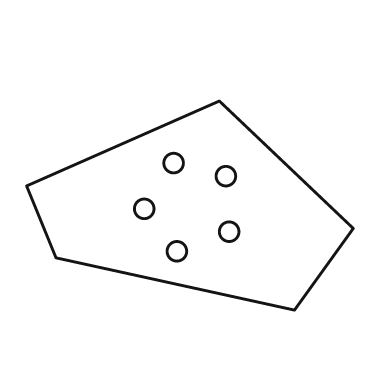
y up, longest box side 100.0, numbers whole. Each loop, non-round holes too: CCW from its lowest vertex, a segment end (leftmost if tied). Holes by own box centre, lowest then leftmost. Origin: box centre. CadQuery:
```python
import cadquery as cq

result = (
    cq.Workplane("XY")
    .moveTo(32.0, -32.0)
    .lineTo(50.0, -7.0)
    .lineTo(9.0, 32.0)
    .lineTo(-50.0, 6.0)
    .lineTo(-41.0, -16.0)
    .close()
    .moveTo(-4.0, -14.0)
    .circle(3.0)
    .moveTo(12.0, -8.0)
    .circle(3.0)
    .moveTo(-14.0, -1.0)
    .circle(3.0)
    .moveTo(11.0, 9.0)
    .circle(3.0)
    .moveTo(-5.0, 13.0)
    .circle(3.0)
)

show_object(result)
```